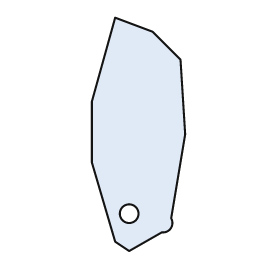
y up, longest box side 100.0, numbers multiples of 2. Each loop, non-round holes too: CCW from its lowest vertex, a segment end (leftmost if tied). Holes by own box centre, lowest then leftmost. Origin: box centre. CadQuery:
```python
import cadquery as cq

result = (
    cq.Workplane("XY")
    .moveTo(-4.0, -50.0)
    .lineTo(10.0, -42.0)
    .threePointArc((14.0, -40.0), (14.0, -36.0))
    .lineTo(20.0, 0.0)
    .lineTo(18.0, 32.0)
    .lineTo(6.0, 44.0)
    .lineTo(-10.0, 50.0)
    .lineTo(-20.0, 14.0)
    .lineTo(-20.0, -12.0)
    .lineTo(-10.0, -46.0)
    .close()
    .moveTo(-4.0, -34.0)
    .circle(4.0)
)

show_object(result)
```